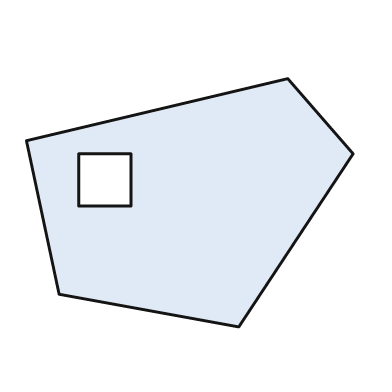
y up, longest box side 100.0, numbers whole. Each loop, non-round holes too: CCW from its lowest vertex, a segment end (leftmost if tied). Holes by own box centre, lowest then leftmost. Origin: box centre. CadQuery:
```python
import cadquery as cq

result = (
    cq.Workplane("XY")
    .moveTo(15.0, -38.0)
    .lineTo(50.0, 15.0)
    .lineTo(30.0, 38.0)
    .lineTo(-50.0, 19.0)
    .lineTo(-40.0, -28.0)
    .close()
    .moveTo(-34.0, -1.0)
    .lineTo(-18.0, -1.0)
    .lineTo(-18.0, 15.0)
    .lineTo(-34.0, 15.0)
    .close()
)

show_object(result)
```